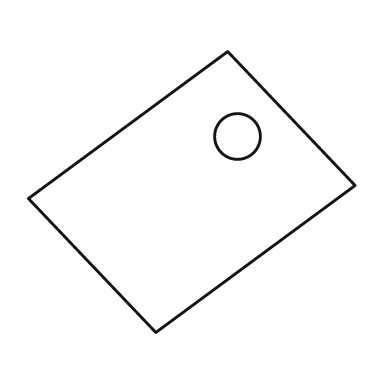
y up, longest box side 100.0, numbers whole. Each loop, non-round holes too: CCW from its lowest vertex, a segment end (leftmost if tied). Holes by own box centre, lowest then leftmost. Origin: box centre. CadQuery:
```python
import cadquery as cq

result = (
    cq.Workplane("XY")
    .moveTo(-11.0, -43.0)
    .lineTo(50.0, 2.0)
    .lineTo(11.0, 43.0)
    .lineTo(-50.0, -2.0)
    .close()
    .moveTo(14.0, 17.0)
    .circle(7.0)
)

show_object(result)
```